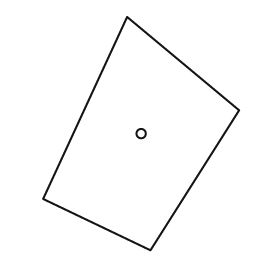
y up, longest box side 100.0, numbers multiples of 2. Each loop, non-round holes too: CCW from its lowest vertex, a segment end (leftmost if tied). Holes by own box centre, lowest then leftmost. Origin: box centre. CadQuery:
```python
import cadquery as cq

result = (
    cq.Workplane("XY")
    .moveTo(4.0, -50.0)
    .lineTo(42.0, 10.0)
    .lineTo(-6.0, 50.0)
    .lineTo(-42.0, -28.0)
    .close()
    .moveTo(0.0, 0.0)
    .circle(2.0)
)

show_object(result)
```